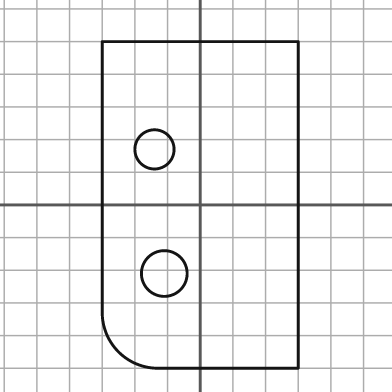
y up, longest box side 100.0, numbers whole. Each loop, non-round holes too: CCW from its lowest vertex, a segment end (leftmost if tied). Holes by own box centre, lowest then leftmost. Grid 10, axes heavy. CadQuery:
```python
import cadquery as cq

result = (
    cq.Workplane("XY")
    .moveTo(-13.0, -50.0)
    .lineTo(30.0, -50.0)
    .lineTo(30.0, 50.0)
    .lineTo(-30.0, 50.0)
    .lineTo(-30.0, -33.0)
    .threePointArc((-25.0, -45.0), (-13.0, -50.0))
    .close()
    .moveTo(-11.0, -21.0)
    .circle(7.0)
    .moveTo(-14.0, 17.0)
    .circle(6.0)
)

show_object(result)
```